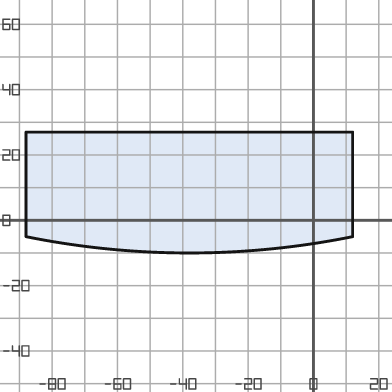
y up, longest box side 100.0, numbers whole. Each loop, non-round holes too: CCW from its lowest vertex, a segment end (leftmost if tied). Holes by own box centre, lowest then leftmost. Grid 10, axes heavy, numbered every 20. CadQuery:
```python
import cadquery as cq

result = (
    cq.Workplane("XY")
    .moveTo(-88.0, -5.0)
    .threePointArc((-38.0, -10.0), (12.0, -5.0))
    .lineTo(12.0, 27.0)
    .lineTo(-88.0, 27.0)
    .close()
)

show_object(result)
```